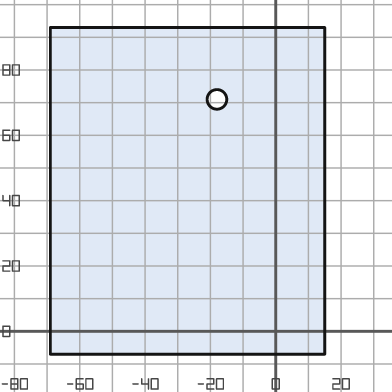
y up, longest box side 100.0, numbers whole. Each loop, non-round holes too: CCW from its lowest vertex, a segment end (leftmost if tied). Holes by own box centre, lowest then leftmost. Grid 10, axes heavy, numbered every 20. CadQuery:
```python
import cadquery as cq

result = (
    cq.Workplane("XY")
    .moveTo(-69.0, -7.0)
    .lineTo(15.0, -7.0)
    .lineTo(15.0, 93.0)
    .lineTo(-69.0, 93.0)
    .close()
    .moveTo(-18.0, 71.0)
    .circle(3.0)
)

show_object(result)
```